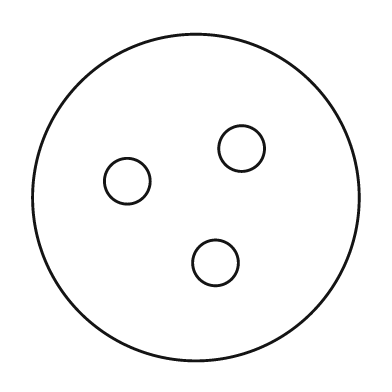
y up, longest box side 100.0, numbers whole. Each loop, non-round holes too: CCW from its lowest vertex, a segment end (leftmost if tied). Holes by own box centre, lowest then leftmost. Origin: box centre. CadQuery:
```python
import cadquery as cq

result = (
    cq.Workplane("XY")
    .moveTo(0.0, 0.0)
    .circle(50.0)
    .moveTo(6.0, -20.0)
    .circle(7.0)
    .moveTo(-21.0, 5.0)
    .circle(7.0)
    .moveTo(14.0, 15.0)
    .circle(7.0)
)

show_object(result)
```